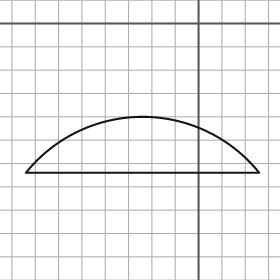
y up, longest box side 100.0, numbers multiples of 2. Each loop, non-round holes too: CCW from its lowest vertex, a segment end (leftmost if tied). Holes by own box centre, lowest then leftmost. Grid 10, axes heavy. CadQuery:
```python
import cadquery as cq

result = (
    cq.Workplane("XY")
    .moveTo(-74.0, -64.0)
    .lineTo(26.0, -64.0)
    .threePointArc((-24.0, -40.0), (-74.0, -64.0))
    .close()
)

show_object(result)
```